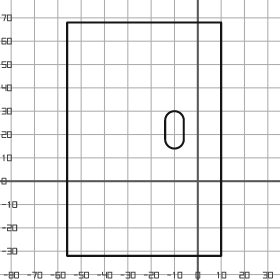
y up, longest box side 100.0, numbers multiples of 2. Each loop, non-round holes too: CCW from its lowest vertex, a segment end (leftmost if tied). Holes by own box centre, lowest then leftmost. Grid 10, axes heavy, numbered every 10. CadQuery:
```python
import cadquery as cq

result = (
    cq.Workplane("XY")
    .moveTo(-56.0, -32.0)
    .lineTo(10.0, -32.0)
    .lineTo(10.0, 68.0)
    .lineTo(-56.0, 68.0)
    .close()
    .moveTo(-14.0, 18.0)
    .threePointArc((-10.0, 14.0), (-6.0, 18.0))
    .lineTo(-6.0, 26.0)
    .threePointArc((-10.0, 30.0), (-14.0, 26.0))
    .close()
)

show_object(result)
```